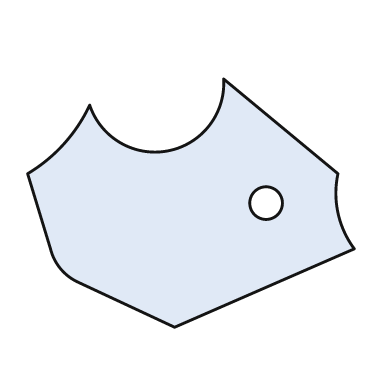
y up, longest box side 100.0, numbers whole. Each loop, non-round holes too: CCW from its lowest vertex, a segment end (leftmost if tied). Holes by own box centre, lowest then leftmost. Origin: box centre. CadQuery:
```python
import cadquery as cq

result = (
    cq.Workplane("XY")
    .moveTo(-5.0, -38.0)
    .lineTo(50.0, -14.0)
    .threePointArc((45.0, -3.0), (45.0, 9.0))
    .lineTo(10.0, 38.0)
    .threePointArc((-7.0, 16.0), (-31.0, 30.0))
    .threePointArc((-39.0, 18.0), (-50.0, 9.0))
    .lineTo(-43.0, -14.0)
    .threePointArc((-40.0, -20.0), (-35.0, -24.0))
    .close()
    .moveTo(23.0, 0.0)
    .circle(5.0)
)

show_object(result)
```